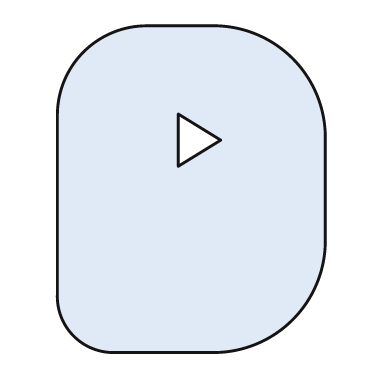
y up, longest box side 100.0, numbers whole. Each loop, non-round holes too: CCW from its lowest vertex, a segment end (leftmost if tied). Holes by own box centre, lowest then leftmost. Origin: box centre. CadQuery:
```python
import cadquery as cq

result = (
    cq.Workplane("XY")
    .moveTo(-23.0, -50.0)
    .lineTo(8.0, -50.0)
    .threePointArc((31.0, -40.0), (41.0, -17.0))
    .lineTo(41.0, 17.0)
    .threePointArc((31.0, 40.0), (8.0, 50.0))
    .lineTo(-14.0, 50.0)
    .threePointArc((-33.0, 42.0), (-41.0, 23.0))
    .lineTo(-41.0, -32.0)
    .threePointArc((-36.0, -45.0), (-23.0, -50.0))
    .close()
    .moveTo(-4.0, 7.0)
    .lineTo(9.0, 15.0)
    .lineTo(-4.0, 23.0)
    .close()
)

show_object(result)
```